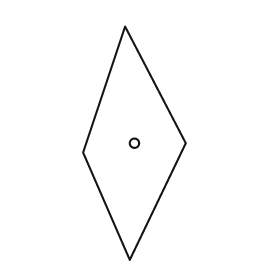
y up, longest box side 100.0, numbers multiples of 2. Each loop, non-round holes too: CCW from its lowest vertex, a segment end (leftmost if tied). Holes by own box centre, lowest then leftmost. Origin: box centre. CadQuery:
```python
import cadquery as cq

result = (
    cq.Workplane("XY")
    .moveTo(-2.0, -50.0)
    .lineTo(22.0, 0.0)
    .lineTo(-4.0, 50.0)
    .lineTo(-22.0, -4.0)
    .close()
    .moveTo(0.0, 0.0)
    .circle(2.0)
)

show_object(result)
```